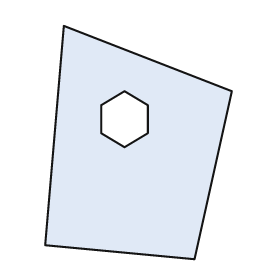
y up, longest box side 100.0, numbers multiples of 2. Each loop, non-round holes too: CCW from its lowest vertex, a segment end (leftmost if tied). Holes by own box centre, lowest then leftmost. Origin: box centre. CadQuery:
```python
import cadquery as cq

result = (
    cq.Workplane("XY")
    .moveTo(24.0, -50.0)
    .lineTo(40.0, 22.0)
    .lineTo(-32.0, 50.0)
    .lineTo(-40.0, -44.0)
    .close()
    .moveTo(-6.0, -2.0)
    .lineTo(4.0, 4.0)
    .lineTo(4.0, 16.0)
    .lineTo(-6.0, 22.0)
    .lineTo(-16.0, 16.0)
    .lineTo(-16.0, 4.0)
    .close()
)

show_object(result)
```